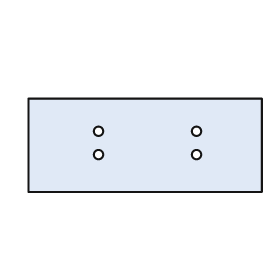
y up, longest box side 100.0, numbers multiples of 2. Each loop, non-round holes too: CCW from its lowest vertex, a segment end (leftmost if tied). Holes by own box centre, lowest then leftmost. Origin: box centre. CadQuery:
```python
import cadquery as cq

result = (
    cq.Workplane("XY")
    .moveTo(-50.0, -20.0)
    .lineTo(50.0, -20.0)
    .lineTo(50.0, 20.0)
    .lineTo(-50.0, 20.0)
    .close()
    .moveTo(-20.0, -4.0)
    .circle(2.0)
    .moveTo(22.0, -4.0)
    .circle(2.0)
    .moveTo(-20.0, 6.0)
    .circle(2.0)
    .moveTo(22.0, 6.0)
    .circle(2.0)
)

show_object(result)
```